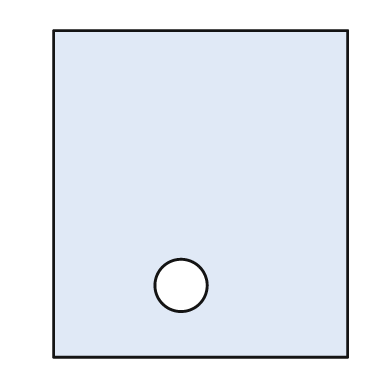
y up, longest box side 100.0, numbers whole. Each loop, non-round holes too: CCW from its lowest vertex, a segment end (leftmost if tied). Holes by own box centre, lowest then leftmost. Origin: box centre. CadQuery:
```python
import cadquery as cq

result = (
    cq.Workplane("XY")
    .moveTo(-45.0, -50.0)
    .lineTo(45.0, -50.0)
    .lineTo(45.0, 50.0)
    .lineTo(-45.0, 50.0)
    .close()
    .moveTo(-6.0, -28.0)
    .circle(8.0)
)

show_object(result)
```